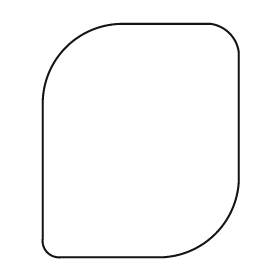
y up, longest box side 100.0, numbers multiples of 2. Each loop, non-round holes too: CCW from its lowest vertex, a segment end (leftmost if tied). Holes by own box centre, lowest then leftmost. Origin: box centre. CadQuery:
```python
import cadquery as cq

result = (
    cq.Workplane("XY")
    .moveTo(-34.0, -50.0)
    .lineTo(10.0, -50.0)
    .threePointArc((32.0, -40.0), (42.0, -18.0))
    .lineTo(42.0, 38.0)
    .threePointArc((38.0, 46.0), (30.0, 50.0))
    .lineTo(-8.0, 50.0)
    .threePointArc((-32.0, 40.0), (-42.0, 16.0))
    .lineTo(-42.0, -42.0)
    .threePointArc((-40.0, -48.0), (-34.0, -50.0))
    .close()
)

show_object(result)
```